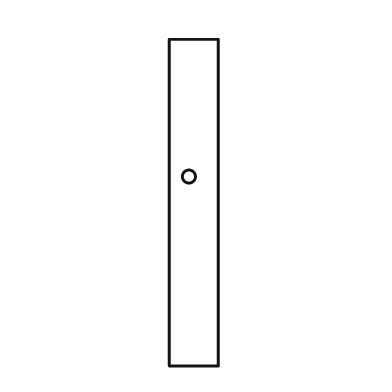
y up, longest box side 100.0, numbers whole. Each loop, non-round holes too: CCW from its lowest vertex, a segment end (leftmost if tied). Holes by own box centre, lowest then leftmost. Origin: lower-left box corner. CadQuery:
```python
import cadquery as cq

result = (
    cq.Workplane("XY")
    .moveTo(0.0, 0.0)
    .lineTo(15.0, 0.0)
    .lineTo(15.0, 100.0)
    .lineTo(0.0, 100.0)
    .close()
    .moveTo(6.0, 58.0)
    .circle(2.0)
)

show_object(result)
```